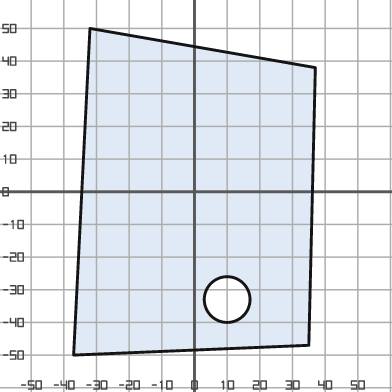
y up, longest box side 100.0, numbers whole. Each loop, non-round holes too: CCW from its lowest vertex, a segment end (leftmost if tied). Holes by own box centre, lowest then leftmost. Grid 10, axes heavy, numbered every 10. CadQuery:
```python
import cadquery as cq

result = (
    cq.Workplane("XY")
    .moveTo(-37.0, -50.0)
    .lineTo(35.0, -47.0)
    .lineTo(37.0, 38.0)
    .lineTo(-32.0, 50.0)
    .close()
    .moveTo(10.0, -33.0)
    .circle(7.0)
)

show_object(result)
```